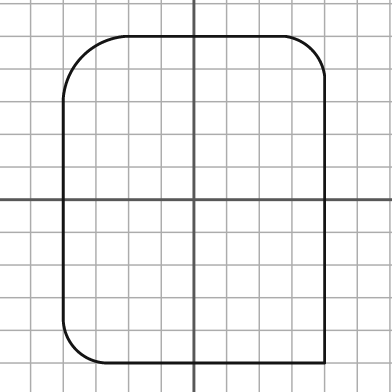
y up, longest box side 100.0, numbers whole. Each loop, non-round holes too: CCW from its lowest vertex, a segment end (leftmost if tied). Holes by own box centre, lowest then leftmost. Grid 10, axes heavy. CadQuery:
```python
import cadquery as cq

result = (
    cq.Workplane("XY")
    .moveTo(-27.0, -50.0)
    .lineTo(40.0, -50.0)
    .lineTo(40.0, 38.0)
    .threePointArc((36.0, 46.0), (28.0, 50.0))
    .lineTo(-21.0, 50.0)
    .threePointArc((-34.0, 44.0), (-40.0, 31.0))
    .lineTo(-40.0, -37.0)
    .threePointArc((-36.0, -46.0), (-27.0, -50.0))
    .close()
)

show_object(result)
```